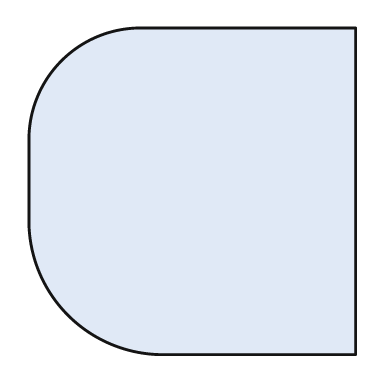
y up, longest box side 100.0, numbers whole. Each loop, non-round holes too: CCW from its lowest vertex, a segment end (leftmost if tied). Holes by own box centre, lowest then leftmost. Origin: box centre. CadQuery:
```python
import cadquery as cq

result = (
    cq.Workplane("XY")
    .moveTo(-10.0, -50.0)
    .lineTo(50.0, -50.0)
    .lineTo(50.0, 50.0)
    .lineTo(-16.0, 50.0)
    .threePointArc((-40.0, 40.0), (-50.0, 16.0))
    .lineTo(-50.0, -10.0)
    .threePointArc((-38.0, -38.0), (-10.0, -50.0))
    .close()
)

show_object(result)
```